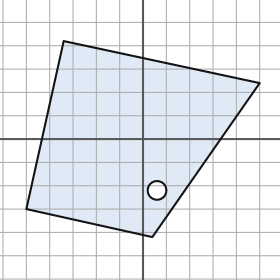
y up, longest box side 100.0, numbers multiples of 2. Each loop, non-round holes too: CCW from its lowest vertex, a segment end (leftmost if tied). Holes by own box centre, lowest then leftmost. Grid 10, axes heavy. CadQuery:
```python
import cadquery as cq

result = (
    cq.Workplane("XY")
    .moveTo(4.0, -42.0)
    .lineTo(50.0, 24.0)
    .lineTo(-34.0, 42.0)
    .lineTo(-50.0, -30.0)
    .close()
    .moveTo(6.0, -22.0)
    .circle(4.0)
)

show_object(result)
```